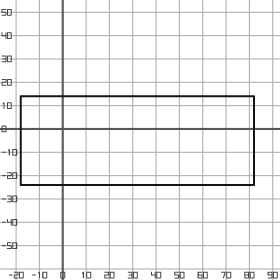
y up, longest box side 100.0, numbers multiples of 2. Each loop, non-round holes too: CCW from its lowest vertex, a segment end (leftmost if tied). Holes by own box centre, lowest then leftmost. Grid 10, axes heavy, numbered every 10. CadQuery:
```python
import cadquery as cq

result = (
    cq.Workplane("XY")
    .moveTo(-18.0, -24.0)
    .lineTo(82.0, -24.0)
    .lineTo(82.0, 14.0)
    .lineTo(-18.0, 14.0)
    .close()
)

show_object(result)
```